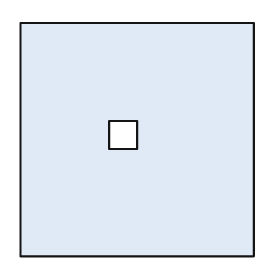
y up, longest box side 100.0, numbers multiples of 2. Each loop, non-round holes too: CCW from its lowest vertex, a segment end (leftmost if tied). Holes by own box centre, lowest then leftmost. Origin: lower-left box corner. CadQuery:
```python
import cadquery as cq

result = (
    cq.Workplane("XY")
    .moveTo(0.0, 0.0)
    .lineTo(100.0, 0.0)
    .lineTo(100.0, 100.0)
    .lineTo(0.0, 100.0)
    .close()
    .moveTo(38.0, 46.0)
    .lineTo(50.0, 46.0)
    .lineTo(50.0, 58.0)
    .lineTo(38.0, 58.0)
    .close()
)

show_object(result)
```